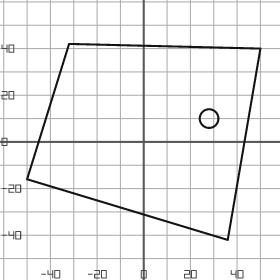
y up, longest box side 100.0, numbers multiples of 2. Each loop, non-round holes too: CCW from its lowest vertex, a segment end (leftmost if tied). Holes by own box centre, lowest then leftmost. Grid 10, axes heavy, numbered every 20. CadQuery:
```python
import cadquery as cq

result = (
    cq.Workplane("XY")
    .moveTo(36.0, -42.0)
    .lineTo(50.0, 40.0)
    .lineTo(-32.0, 42.0)
    .lineTo(-50.0, -16.0)
    .close()
    .moveTo(28.0, 10.0)
    .circle(4.0)
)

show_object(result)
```